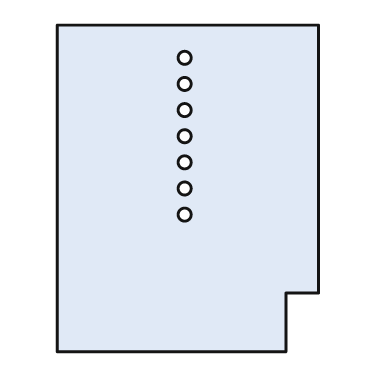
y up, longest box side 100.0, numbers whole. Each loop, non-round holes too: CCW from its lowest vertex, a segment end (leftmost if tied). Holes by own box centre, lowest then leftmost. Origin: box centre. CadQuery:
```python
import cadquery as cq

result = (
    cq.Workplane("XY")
    .moveTo(-40.0, -50.0)
    .lineTo(30.0, -50.0)
    .lineTo(30.0, -32.0)
    .lineTo(40.0, -32.0)
    .lineTo(40.0, 50.0)
    .lineTo(-40.0, 50.0)
    .close()
    .moveTo(-1.0, -8.0)
    .circle(2.0)
    .moveTo(-1.0, 0.0)
    .circle(2.0)
    .moveTo(-1.0, 8.0)
    .circle(2.0)
    .moveTo(-1.0, 16.0)
    .circle(2.0)
    .moveTo(-1.0, 24.0)
    .circle(2.0)
    .moveTo(-1.0, 32.0)
    .circle(2.0)
    .moveTo(-1.0, 40.0)
    .circle(2.0)
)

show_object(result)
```